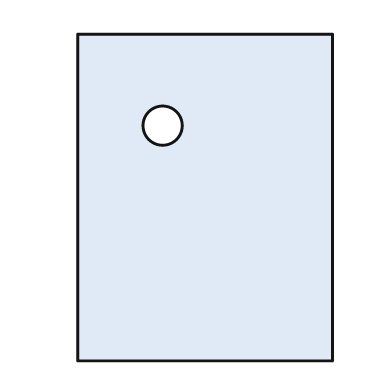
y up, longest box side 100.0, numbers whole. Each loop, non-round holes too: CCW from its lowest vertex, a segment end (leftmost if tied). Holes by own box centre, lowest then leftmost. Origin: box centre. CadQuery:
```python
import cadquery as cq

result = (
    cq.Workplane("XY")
    .moveTo(-39.0, -50.0)
    .lineTo(39.0, -50.0)
    .lineTo(39.0, 50.0)
    .lineTo(-39.0, 50.0)
    .close()
    .moveTo(-13.0, 22.0)
    .circle(6.0)
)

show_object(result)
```